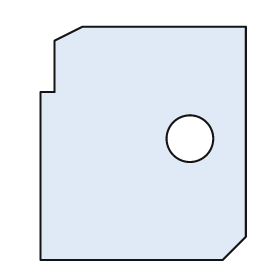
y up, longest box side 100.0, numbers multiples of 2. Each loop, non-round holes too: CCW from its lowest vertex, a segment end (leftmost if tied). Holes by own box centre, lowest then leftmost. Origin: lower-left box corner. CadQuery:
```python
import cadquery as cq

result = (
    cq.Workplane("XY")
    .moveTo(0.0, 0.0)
    .lineTo(78.0, 0.0)
    .lineTo(88.0, 10.0)
    .lineTo(88.0, 100.0)
    .lineTo(18.0, 100.0)
    .lineTo(6.0, 94.0)
    .lineTo(6.0, 72.0)
    .lineTo(0.0, 72.0)
    .close()
    .moveTo(64.0, 52.0)
    .circle(10.0)
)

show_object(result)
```